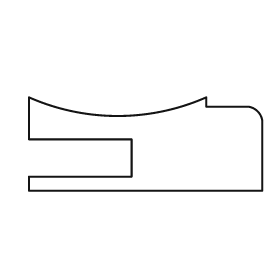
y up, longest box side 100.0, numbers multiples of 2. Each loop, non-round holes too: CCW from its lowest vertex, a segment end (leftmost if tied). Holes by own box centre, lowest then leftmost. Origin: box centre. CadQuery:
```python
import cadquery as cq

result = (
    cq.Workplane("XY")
    .moveTo(-50.0, -20.0)
    .lineTo(50.0, -20.0)
    .lineTo(50.0, 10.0)
    .threePointArc((48.0, 14.0), (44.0, 16.0))
    .lineTo(26.0, 16.0)
    .lineTo(26.0, 20.0)
    .threePointArc((-12.0, 12.0), (-50.0, 20.0))
    .lineTo(-50.0, 2.0)
    .lineTo(-6.0, 2.0)
    .lineTo(-6.0, -14.0)
    .lineTo(-50.0, -14.0)
    .close()
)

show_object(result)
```